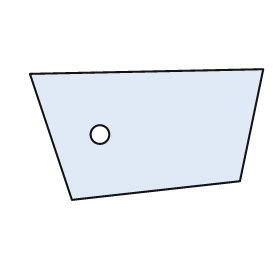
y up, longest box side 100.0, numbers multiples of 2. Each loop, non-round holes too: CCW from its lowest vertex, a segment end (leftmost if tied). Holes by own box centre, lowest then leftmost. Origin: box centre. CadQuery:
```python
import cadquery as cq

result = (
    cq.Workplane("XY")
    .moveTo(-32.0, -28.0)
    .lineTo(40.0, -20.0)
    .lineTo(50.0, 28.0)
    .lineTo(-50.0, 26.0)
    .close()
    .moveTo(-20.0, 0.0)
    .circle(4.0)
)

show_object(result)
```